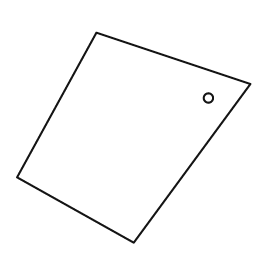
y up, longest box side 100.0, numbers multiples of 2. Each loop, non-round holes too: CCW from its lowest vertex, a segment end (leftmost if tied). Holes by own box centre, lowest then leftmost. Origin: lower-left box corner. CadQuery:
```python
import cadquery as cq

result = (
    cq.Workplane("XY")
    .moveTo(50.0, 0.0)
    .lineTo(100.0, 68.0)
    .lineTo(34.0, 90.0)
    .lineTo(0.0, 28.0)
    .close()
    .moveTo(82.0, 62.0)
    .circle(2.0)
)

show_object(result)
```